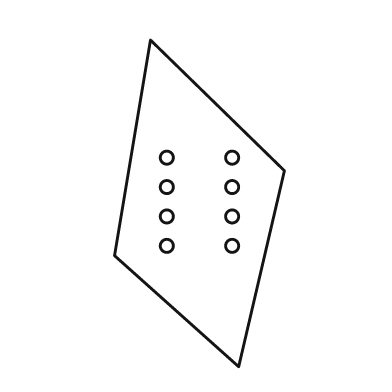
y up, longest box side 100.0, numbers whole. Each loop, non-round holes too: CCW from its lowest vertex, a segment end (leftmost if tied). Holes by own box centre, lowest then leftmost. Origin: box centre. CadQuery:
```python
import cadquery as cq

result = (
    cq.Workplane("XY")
    .moveTo(12.0, -50.0)
    .lineTo(26.0, 10.0)
    .lineTo(-15.0, 50.0)
    .lineTo(-26.0, -16.0)
    .close()
    .moveTo(-10.0, -13.0)
    .circle(2.0)
    .moveTo(10.0, -13.0)
    .circle(2.0)
    .moveTo(-10.0, -4.0)
    .circle(2.0)
    .moveTo(10.0, -4.0)
    .circle(2.0)
    .moveTo(-10.0, 5.0)
    .circle(2.0)
    .moveTo(10.0, 5.0)
    .circle(2.0)
    .moveTo(-10.0, 14.0)
    .circle(2.0)
    .moveTo(10.0, 14.0)
    .circle(2.0)
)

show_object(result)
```